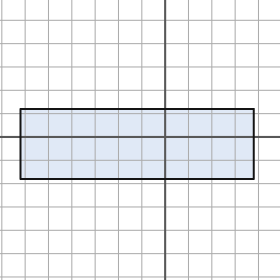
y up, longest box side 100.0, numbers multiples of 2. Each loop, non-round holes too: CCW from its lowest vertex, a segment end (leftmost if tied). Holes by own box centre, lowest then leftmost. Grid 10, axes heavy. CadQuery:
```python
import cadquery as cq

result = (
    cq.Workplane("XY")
    .moveTo(-62.0, -18.0)
    .lineTo(38.0, -18.0)
    .lineTo(38.0, 12.0)
    .lineTo(-62.0, 12.0)
    .close()
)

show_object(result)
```